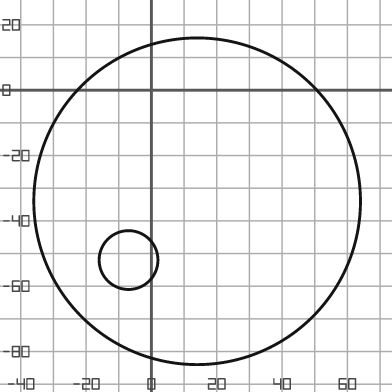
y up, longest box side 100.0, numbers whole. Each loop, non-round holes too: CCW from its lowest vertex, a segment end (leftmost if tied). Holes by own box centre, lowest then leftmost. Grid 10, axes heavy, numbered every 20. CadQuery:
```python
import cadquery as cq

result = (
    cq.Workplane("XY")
    .moveTo(14.0, -34.0)
    .circle(50.0)
    .moveTo(-7.0, -52.0)
    .circle(9.0)
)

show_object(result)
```